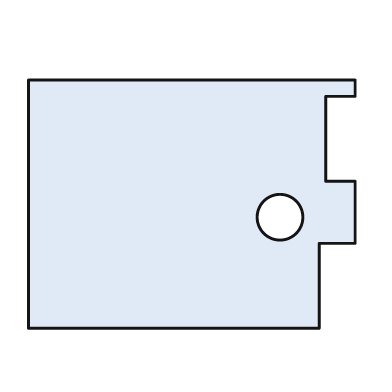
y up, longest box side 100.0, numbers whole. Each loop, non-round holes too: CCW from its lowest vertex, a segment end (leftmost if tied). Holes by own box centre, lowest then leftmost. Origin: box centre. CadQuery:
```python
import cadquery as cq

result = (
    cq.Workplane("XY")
    .moveTo(-50.0, -38.0)
    .lineTo(39.0, -38.0)
    .lineTo(39.0, -12.0)
    .lineTo(50.0, -12.0)
    .lineTo(50.0, 7.0)
    .lineTo(41.0, 7.0)
    .lineTo(41.0, 33.0)
    .lineTo(50.0, 33.0)
    .lineTo(50.0, 38.0)
    .lineTo(-50.0, 38.0)
    .close()
    .moveTo(27.0, -4.0)
    .circle(7.0)
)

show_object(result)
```